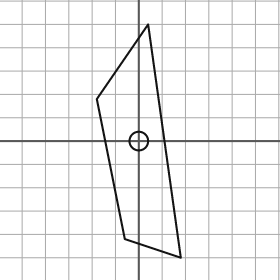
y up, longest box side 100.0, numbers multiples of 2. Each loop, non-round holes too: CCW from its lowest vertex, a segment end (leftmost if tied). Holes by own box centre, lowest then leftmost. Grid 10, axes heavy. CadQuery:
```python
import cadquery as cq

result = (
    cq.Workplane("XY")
    .moveTo(18.0, -50.0)
    .lineTo(4.0, 50.0)
    .lineTo(-18.0, 18.0)
    .lineTo(-6.0, -42.0)
    .close()
    .moveTo(0.0, 0.0)
    .circle(4.0)
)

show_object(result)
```